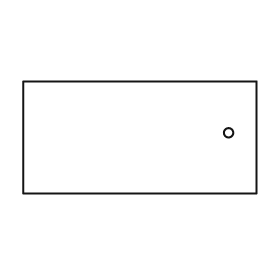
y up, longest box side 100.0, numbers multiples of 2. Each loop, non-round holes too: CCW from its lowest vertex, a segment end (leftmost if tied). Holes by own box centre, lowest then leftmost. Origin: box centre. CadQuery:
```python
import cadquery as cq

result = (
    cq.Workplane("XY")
    .moveTo(-50.0, -24.0)
    .lineTo(50.0, -24.0)
    .lineTo(50.0, 24.0)
    .lineTo(-50.0, 24.0)
    .close()
    .moveTo(38.0, 2.0)
    .circle(2.0)
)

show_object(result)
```